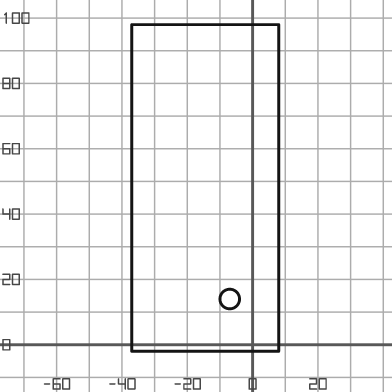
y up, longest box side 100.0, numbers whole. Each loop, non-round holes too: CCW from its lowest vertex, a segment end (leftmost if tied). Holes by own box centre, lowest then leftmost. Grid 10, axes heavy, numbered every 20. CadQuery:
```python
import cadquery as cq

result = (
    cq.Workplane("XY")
    .moveTo(-37.0, -2.0)
    .lineTo(8.0, -2.0)
    .lineTo(8.0, 98.0)
    .lineTo(-37.0, 98.0)
    .close()
    .moveTo(-7.0, 14.0)
    .circle(3.0)
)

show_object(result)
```